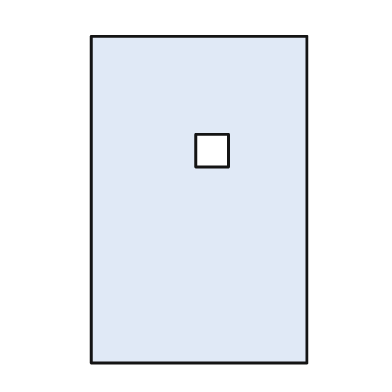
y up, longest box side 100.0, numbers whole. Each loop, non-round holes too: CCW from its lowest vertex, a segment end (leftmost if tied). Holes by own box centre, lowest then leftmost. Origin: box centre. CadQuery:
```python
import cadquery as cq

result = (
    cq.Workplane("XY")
    .moveTo(-33.0, -50.0)
    .lineTo(33.0, -50.0)
    .lineTo(33.0, 50.0)
    .lineTo(-33.0, 50.0)
    .close()
    .moveTo(-1.0, 10.0)
    .lineTo(9.0, 10.0)
    .lineTo(9.0, 20.0)
    .lineTo(-1.0, 20.0)
    .close()
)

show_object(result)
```